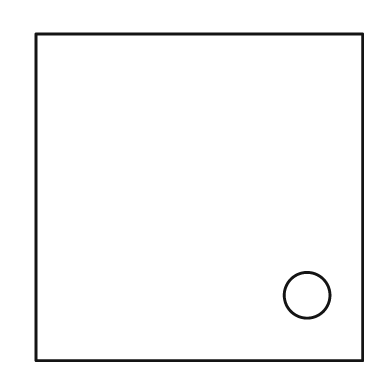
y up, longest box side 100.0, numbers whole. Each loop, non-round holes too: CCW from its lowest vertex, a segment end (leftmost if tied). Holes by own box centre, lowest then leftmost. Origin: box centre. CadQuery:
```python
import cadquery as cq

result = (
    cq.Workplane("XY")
    .moveTo(-50.0, -50.0)
    .lineTo(50.0, -50.0)
    .lineTo(50.0, 50.0)
    .lineTo(-50.0, 50.0)
    .close()
    .moveTo(33.0, -30.0)
    .circle(7.0)
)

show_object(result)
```